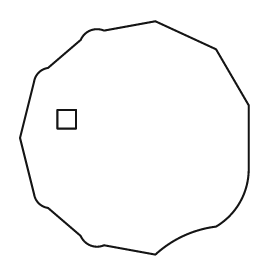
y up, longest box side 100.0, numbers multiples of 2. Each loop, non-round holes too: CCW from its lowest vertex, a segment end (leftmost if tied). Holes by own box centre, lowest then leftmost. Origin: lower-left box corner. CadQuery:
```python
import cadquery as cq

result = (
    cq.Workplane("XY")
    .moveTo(58.0, 0.0)
    .threePointArc((70.0, 8.0), (84.0, 12.0))
    .threePointArc((94.0, 22.0), (98.0, 36.0))
    .lineTo(98.0, 64.0)
    .lineTo(84.0, 88.0)
    .lineTo(58.0, 100.0)
    .lineTo(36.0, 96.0)
    .threePointArc((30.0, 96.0), (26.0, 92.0))
    .lineTo(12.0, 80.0)
    .threePointArc((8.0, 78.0), (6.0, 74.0))
    .lineTo(0.0, 50.0)
    .lineTo(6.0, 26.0)
    .threePointArc((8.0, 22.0), (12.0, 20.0))
    .lineTo(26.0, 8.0)
    .threePointArc((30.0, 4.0), (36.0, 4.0))
    .close()
    .moveTo(16.0, 54.0)
    .lineTo(24.0, 54.0)
    .lineTo(24.0, 62.0)
    .lineTo(16.0, 62.0)
    .close()
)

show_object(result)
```